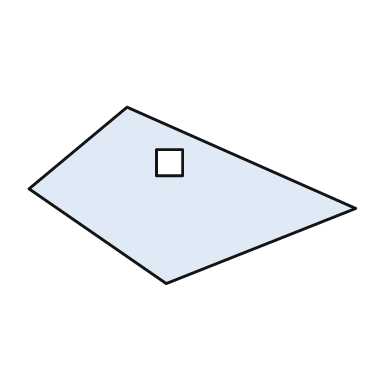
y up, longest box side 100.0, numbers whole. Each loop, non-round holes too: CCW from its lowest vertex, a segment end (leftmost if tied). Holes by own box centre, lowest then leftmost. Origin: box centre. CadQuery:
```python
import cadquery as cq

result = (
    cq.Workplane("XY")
    .moveTo(-8.0, -27.0)
    .lineTo(50.0, -4.0)
    .lineTo(-20.0, 27.0)
    .lineTo(-50.0, 2.0)
    .close()
    .moveTo(-11.0, 6.0)
    .lineTo(-3.0, 6.0)
    .lineTo(-3.0, 14.0)
    .lineTo(-11.0, 14.0)
    .close()
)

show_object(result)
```